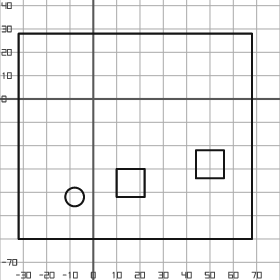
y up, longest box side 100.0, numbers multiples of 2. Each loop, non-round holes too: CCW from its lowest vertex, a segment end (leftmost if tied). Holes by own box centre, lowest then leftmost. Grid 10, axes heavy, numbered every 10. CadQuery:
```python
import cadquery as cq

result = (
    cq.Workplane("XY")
    .moveTo(-32.0, -60.0)
    .lineTo(68.0, -60.0)
    .lineTo(68.0, 28.0)
    .lineTo(-32.0, 28.0)
    .close()
    .moveTo(-8.0, -42.0)
    .circle(4.0)
    .moveTo(10.0, -42.0)
    .lineTo(22.0, -42.0)
    .lineTo(22.0, -30.0)
    .lineTo(10.0, -30.0)
    .close()
    .moveTo(44.0, -34.0)
    .lineTo(56.0, -34.0)
    .lineTo(56.0, -22.0)
    .lineTo(44.0, -22.0)
    .close()
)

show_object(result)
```